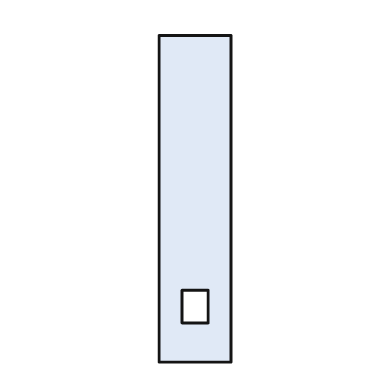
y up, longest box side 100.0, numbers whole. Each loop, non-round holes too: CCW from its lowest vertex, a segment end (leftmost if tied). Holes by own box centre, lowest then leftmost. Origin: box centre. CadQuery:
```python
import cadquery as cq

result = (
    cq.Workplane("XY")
    .moveTo(-11.0, -50.0)
    .lineTo(11.0, -50.0)
    .lineTo(11.0, 50.0)
    .lineTo(-11.0, 50.0)
    .close()
    .moveTo(-4.0, -38.0)
    .lineTo(4.0, -38.0)
    .lineTo(4.0, -28.0)
    .lineTo(-4.0, -28.0)
    .close()
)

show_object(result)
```